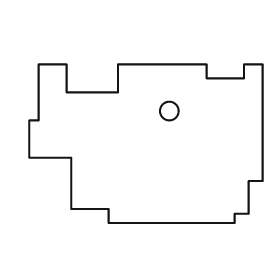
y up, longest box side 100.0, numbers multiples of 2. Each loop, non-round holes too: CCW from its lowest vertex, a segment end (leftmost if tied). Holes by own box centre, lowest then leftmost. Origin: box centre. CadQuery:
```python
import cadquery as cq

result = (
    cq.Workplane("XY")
    .moveTo(-16.0, -34.0)
    .lineTo(38.0, -34.0)
    .lineTo(38.0, -30.0)
    .lineTo(44.0, -30.0)
    .lineTo(44.0, -16.0)
    .lineTo(50.0, -16.0)
    .lineTo(50.0, 34.0)
    .lineTo(42.0, 34.0)
    .lineTo(42.0, 28.0)
    .lineTo(26.0, 28.0)
    .lineTo(26.0, 34.0)
    .lineTo(-12.0, 34.0)
    .lineTo(-12.0, 22.0)
    .lineTo(-34.0, 22.0)
    .lineTo(-34.0, 34.0)
    .lineTo(-46.0, 34.0)
    .lineTo(-46.0, 10.0)
    .lineTo(-50.0, 10.0)
    .lineTo(-50.0, -6.0)
    .lineTo(-32.0, -6.0)
    .lineTo(-32.0, -28.0)
    .lineTo(-16.0, -28.0)
    .close()
    .moveTo(10.0, 14.0)
    .circle(4.0)
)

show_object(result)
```